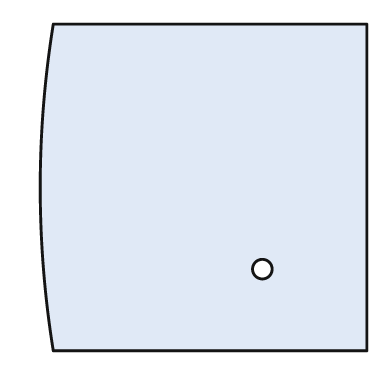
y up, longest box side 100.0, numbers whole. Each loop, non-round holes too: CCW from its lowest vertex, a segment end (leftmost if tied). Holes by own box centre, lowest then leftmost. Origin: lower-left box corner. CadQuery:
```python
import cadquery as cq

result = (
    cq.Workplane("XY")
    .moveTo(4.0, 0.0)
    .lineTo(100.0, 0.0)
    .lineTo(100.0, 100.0)
    .lineTo(4.0, 100.0)
    .threePointArc((0.0, 50.0), (4.0, 0.0))
    .close()
    .moveTo(68.0, 25.0)
    .circle(3.0)
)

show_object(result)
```